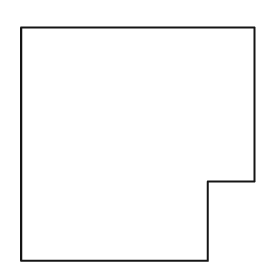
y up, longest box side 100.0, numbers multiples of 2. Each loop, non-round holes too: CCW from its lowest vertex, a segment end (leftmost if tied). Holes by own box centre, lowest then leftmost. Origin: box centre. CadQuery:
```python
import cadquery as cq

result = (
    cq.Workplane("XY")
    .moveTo(-50.0, -50.0)
    .lineTo(30.0, -50.0)
    .lineTo(30.0, -16.0)
    .lineTo(50.0, -16.0)
    .lineTo(50.0, 50.0)
    .lineTo(-50.0, 50.0)
    .close()
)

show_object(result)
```